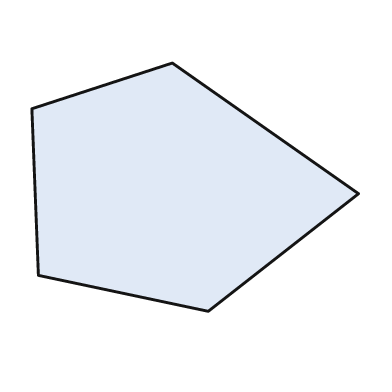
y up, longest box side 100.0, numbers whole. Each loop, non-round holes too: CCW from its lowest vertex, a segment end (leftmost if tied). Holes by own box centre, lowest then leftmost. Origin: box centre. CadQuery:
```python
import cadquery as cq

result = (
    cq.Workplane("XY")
    .moveTo(4.0, -38.0)
    .lineTo(50.0, -2.0)
    .lineTo(-7.0, 38.0)
    .lineTo(-50.0, 24.0)
    .lineTo(-48.0, -27.0)
    .close()
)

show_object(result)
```